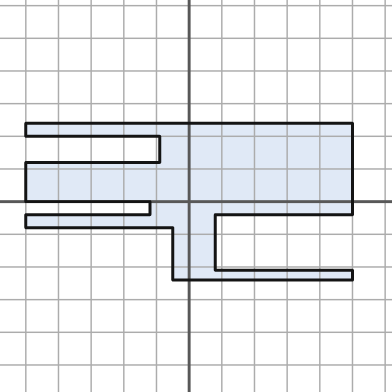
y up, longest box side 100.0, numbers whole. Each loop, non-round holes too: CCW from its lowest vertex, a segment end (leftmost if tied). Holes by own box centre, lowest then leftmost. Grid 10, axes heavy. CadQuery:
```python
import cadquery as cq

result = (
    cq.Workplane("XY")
    .moveTo(-5.0, -24.0)
    .lineTo(50.0, -24.0)
    .lineTo(50.0, -21.0)
    .lineTo(8.0, -21.0)
    .lineTo(8.0, -4.0)
    .lineTo(50.0, -4.0)
    .lineTo(50.0, 24.0)
    .lineTo(-50.0, 24.0)
    .lineTo(-50.0, 20.0)
    .lineTo(-9.0, 20.0)
    .lineTo(-9.0, 12.0)
    .lineTo(-50.0, 12.0)
    .lineTo(-50.0, 0.0)
    .lineTo(-12.0, 0.0)
    .lineTo(-12.0, -4.0)
    .lineTo(-50.0, -4.0)
    .lineTo(-50.0, -8.0)
    .lineTo(-5.0, -8.0)
    .close()
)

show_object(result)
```